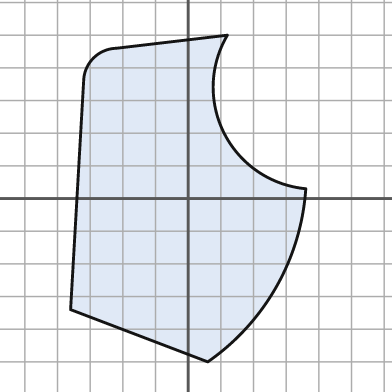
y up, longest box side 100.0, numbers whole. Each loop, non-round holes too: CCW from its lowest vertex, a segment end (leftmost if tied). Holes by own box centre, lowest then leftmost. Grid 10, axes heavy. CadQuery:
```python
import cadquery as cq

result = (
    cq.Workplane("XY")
    .moveTo(6.0, -50.0)
    .threePointArc((27.0, -27.0), (36.0, 3.0))
    .threePointArc((11.0, 20.0), (12.0, 50.0))
    .lineTo(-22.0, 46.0)
    .threePointArc((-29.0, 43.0), (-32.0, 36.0))
    .lineTo(-36.0, -34.0)
    .close()
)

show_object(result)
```